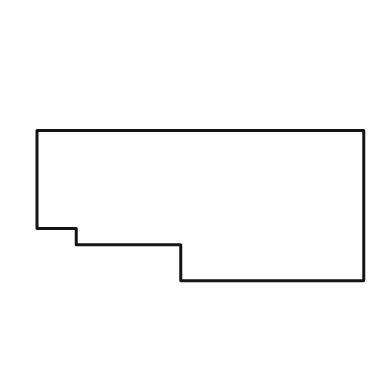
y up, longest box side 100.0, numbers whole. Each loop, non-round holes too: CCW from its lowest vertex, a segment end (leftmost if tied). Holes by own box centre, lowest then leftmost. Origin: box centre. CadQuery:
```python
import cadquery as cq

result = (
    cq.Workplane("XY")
    .moveTo(-6.0, -23.0)
    .lineTo(50.0, -23.0)
    .lineTo(50.0, 23.0)
    .lineTo(-50.0, 23.0)
    .lineTo(-50.0, -7.0)
    .lineTo(-38.0, -7.0)
    .lineTo(-38.0, -12.0)
    .lineTo(-6.0, -12.0)
    .close()
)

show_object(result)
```